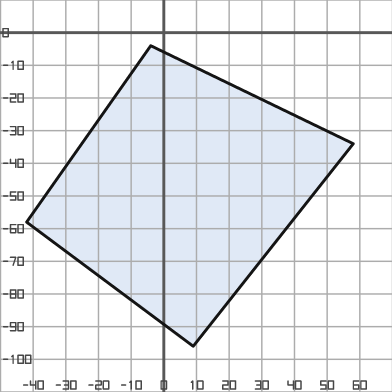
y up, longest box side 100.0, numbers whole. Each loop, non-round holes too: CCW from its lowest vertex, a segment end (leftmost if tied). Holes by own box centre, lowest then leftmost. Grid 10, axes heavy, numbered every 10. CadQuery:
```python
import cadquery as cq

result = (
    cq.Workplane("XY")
    .moveTo(9.0, -96.0)
    .lineTo(58.0, -34.0)
    .lineTo(-4.0, -4.0)
    .lineTo(-42.0, -58.0)
    .close()
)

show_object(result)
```